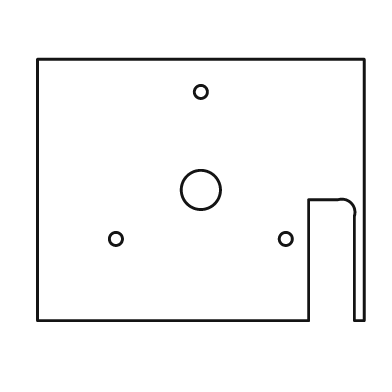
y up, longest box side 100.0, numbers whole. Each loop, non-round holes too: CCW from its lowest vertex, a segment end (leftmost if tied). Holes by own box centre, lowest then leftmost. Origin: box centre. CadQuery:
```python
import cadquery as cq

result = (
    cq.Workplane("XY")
    .moveTo(-50.0, -40.0)
    .lineTo(33.0, -40.0)
    .lineTo(33.0, -3.0)
    .lineTo(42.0, -3.0)
    .threePointArc((46.0, -4.0), (47.0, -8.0))
    .lineTo(47.0, -40.0)
    .lineTo(50.0, -40.0)
    .lineTo(50.0, 40.0)
    .lineTo(-50.0, 40.0)
    .close()
    .moveTo(-26.0, -15.0)
    .circle(2.0)
    .moveTo(26.0, -15.0)
    .circle(2.0)
    .moveTo(0.0, 0.0)
    .circle(6.0)
    .moveTo(0.0, 30.0)
    .circle(2.0)
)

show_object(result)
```